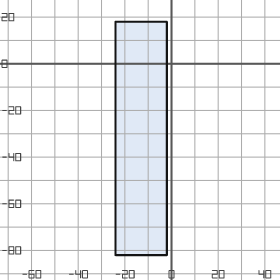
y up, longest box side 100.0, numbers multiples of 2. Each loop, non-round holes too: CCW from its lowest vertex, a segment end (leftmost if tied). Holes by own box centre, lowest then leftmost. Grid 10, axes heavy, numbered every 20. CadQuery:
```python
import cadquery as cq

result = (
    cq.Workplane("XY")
    .moveTo(-24.0, -82.0)
    .lineTo(-2.0, -82.0)
    .lineTo(-2.0, 18.0)
    .lineTo(-24.0, 18.0)
    .close()
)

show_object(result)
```